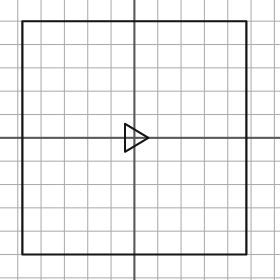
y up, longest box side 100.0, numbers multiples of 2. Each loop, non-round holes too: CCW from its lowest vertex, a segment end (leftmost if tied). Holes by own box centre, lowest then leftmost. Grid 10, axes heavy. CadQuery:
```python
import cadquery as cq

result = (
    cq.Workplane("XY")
    .moveTo(-48.0, -50.0)
    .lineTo(48.0, -50.0)
    .lineTo(48.0, 50.0)
    .lineTo(-48.0, 50.0)
    .close()
    .moveTo(-4.0, -6.0)
    .lineTo(6.0, 0.0)
    .lineTo(-4.0, 6.0)
    .close()
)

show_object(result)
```